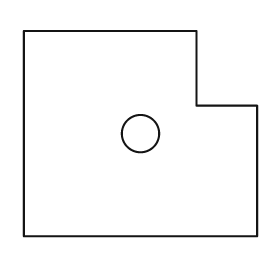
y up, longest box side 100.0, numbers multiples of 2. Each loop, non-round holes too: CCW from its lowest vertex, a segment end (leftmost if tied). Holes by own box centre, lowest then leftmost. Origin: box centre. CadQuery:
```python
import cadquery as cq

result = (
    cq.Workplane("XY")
    .moveTo(-50.0, -44.0)
    .lineTo(50.0, -44.0)
    .lineTo(50.0, 12.0)
    .lineTo(24.0, 12.0)
    .lineTo(24.0, 44.0)
    .lineTo(-50.0, 44.0)
    .close()
    .moveTo(0.0, 0.0)
    .circle(8.0)
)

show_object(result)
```